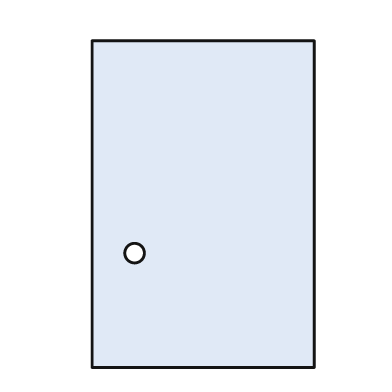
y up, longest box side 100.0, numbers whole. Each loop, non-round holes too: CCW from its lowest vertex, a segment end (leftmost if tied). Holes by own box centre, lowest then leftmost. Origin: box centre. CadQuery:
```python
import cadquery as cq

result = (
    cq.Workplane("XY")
    .moveTo(-34.0, -50.0)
    .lineTo(34.0, -50.0)
    .lineTo(34.0, 50.0)
    .lineTo(-34.0, 50.0)
    .close()
    .moveTo(-21.0, -15.0)
    .circle(3.0)
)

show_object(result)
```